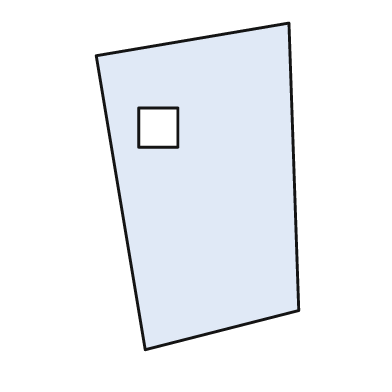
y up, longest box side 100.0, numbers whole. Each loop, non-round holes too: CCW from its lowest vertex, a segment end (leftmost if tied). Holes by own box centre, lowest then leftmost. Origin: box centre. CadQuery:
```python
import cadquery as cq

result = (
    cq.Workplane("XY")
    .moveTo(-16.0, -50.0)
    .lineTo(31.0, -38.0)
    .lineTo(28.0, 50.0)
    .lineTo(-31.0, 40.0)
    .close()
    .moveTo(-18.0, 12.0)
    .lineTo(-6.0, 12.0)
    .lineTo(-6.0, 24.0)
    .lineTo(-18.0, 24.0)
    .close()
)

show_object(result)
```